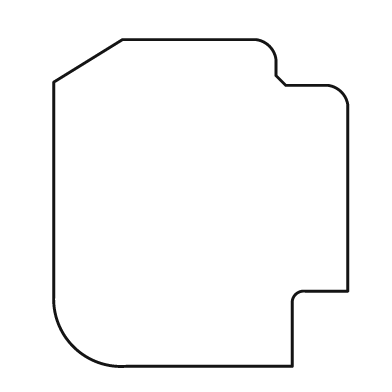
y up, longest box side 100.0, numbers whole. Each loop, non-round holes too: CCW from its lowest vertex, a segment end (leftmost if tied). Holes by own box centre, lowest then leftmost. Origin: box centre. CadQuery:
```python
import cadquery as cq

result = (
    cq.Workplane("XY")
    .moveTo(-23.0, -50.0)
    .lineTo(28.0, -50.0)
    .lineTo(28.0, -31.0)
    .threePointArc((29.0, -28.0), (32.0, -27.0))
    .lineTo(45.0, -27.0)
    .lineTo(45.0, 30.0)
    .threePointArc((43.0, 34.0), (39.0, 36.0))
    .lineTo(26.0, 36.0)
    .lineTo(23.0, 39.0)
    .lineTo(23.0, 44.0)
    .threePointArc((21.0, 48.0), (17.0, 50.0))
    .lineTo(-24.0, 50.0)
    .lineTo(-45.0, 37.0)
    .lineTo(-45.0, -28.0)
    .threePointArc((-39.0, -44.0), (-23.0, -50.0))
    .close()
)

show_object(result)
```